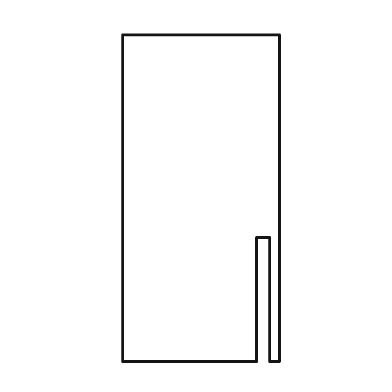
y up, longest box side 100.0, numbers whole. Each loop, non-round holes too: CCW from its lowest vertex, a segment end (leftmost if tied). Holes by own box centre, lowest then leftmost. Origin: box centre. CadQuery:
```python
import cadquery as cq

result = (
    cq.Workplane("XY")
    .moveTo(-24.0, -50.0)
    .lineTo(17.0, -50.0)
    .lineTo(17.0, -12.0)
    .lineTo(21.0, -12.0)
    .lineTo(21.0, -50.0)
    .lineTo(24.0, -50.0)
    .lineTo(24.0, 50.0)
    .lineTo(-24.0, 50.0)
    .close()
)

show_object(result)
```